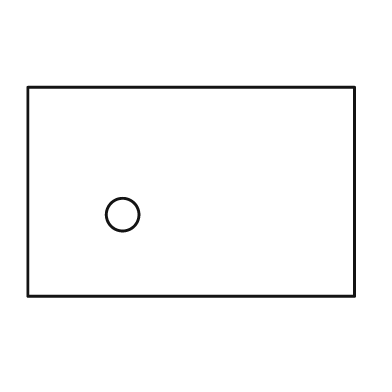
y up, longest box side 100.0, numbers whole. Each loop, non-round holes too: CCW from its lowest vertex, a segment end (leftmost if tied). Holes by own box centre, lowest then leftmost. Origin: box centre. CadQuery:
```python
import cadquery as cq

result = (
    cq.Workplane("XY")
    .moveTo(-50.0, -32.0)
    .lineTo(50.0, -32.0)
    .lineTo(50.0, 32.0)
    .lineTo(-50.0, 32.0)
    .close()
    .moveTo(-21.0, -7.0)
    .circle(5.0)
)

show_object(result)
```